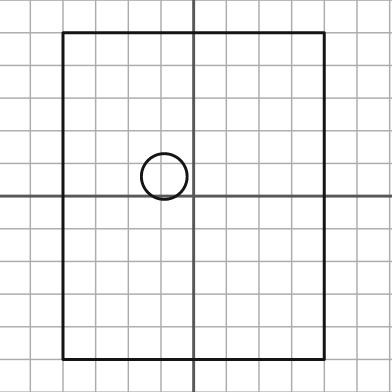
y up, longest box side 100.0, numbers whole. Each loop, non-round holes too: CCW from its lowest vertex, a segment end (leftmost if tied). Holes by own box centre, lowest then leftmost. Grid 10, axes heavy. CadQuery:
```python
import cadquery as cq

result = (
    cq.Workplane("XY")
    .moveTo(-40.0, -50.0)
    .lineTo(40.0, -50.0)
    .lineTo(40.0, 50.0)
    .lineTo(-40.0, 50.0)
    .close()
    .moveTo(-9.0, 6.0)
    .circle(7.0)
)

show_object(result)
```